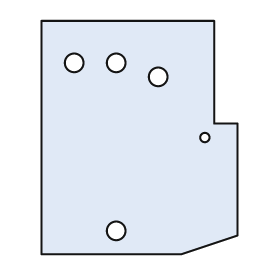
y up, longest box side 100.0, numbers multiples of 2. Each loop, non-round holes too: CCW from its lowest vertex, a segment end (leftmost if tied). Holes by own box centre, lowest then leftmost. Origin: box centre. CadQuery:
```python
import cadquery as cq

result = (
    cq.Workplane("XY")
    .moveTo(-42.0, -50.0)
    .lineTo(18.0, -50.0)
    .lineTo(42.0, -42.0)
    .lineTo(42.0, 6.0)
    .lineTo(32.0, 6.0)
    .lineTo(32.0, 50.0)
    .lineTo(-42.0, 50.0)
    .close()
    .moveTo(-10.0, -40.0)
    .circle(4.0)
    .moveTo(28.0, 0.0)
    .circle(2.0)
    .moveTo(8.0, 26.0)
    .circle(4.0)
    .moveTo(-28.0, 32.0)
    .circle(4.0)
    .moveTo(-10.0, 32.0)
    .circle(4.0)
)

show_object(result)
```